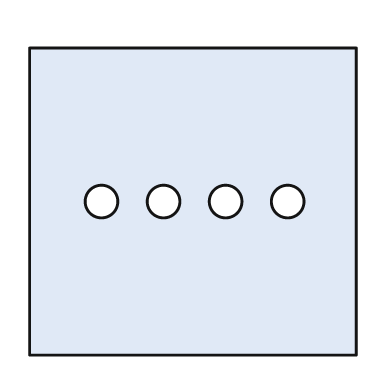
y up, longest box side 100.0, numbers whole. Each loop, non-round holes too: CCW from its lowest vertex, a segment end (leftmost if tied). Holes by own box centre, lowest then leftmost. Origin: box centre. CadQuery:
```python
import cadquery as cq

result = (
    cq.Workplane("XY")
    .moveTo(-50.0, -47.0)
    .lineTo(50.0, -47.0)
    .lineTo(50.0, 47.0)
    .lineTo(-50.0, 47.0)
    .close()
    .moveTo(-28.0, 0.0)
    .circle(5.0)
    .moveTo(-9.0, 0.0)
    .circle(5.0)
    .moveTo(10.0, 0.0)
    .circle(5.0)
    .moveTo(29.0, 0.0)
    .circle(5.0)
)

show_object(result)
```